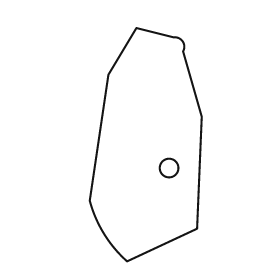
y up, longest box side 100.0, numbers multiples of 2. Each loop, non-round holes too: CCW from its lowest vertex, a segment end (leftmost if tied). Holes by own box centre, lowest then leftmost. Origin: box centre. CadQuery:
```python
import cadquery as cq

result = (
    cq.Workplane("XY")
    .moveTo(-8.0, -50.0)
    .lineTo(22.0, -36.0)
    .lineTo(24.0, 12.0)
    .lineTo(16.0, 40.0)
    .threePointArc((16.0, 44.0), (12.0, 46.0))
    .lineTo(-4.0, 50.0)
    .lineTo(-16.0, 30.0)
    .lineTo(-24.0, -24.0)
    .threePointArc((-18.0, -38.0), (-8.0, -50.0))
    .close()
    .moveTo(10.0, -10.0)
    .circle(4.0)
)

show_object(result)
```